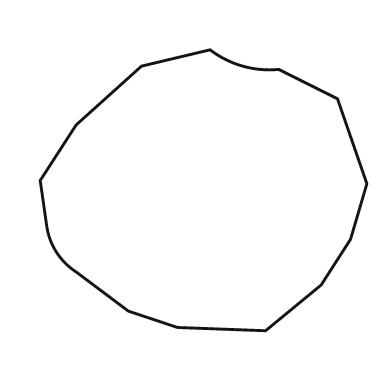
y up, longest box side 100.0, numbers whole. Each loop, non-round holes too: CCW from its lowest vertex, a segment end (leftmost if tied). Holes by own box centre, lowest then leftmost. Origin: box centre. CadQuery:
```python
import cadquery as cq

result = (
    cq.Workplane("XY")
    .moveTo(19.0, -43.0)
    .lineTo(36.0, -29.0)
    .lineTo(45.0, -15.0)
    .lineTo(50.0, 2.0)
    .lineTo(41.0, 28.0)
    .lineTo(23.0, 37.0)
    .threePointArc((12.0, 38.0), (2.0, 43.0))
    .lineTo(-19.0, 38.0)
    .lineTo(-39.0, 20.0)
    .lineTo(-50.0, 3.0)
    .lineTo(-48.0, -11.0)
    .threePointArc((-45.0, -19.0), (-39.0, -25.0))
    .lineTo(-23.0, -37.0)
    .lineTo(-8.0, -42.0)
    .close()
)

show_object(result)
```